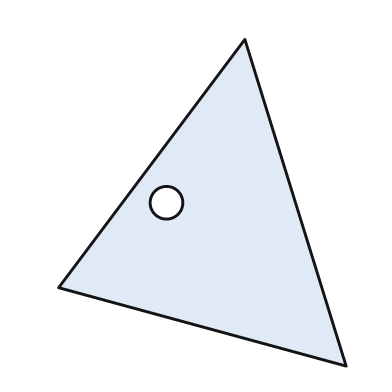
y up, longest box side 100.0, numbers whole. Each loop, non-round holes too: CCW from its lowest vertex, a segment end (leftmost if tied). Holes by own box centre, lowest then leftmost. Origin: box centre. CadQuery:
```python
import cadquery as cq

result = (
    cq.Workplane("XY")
    .moveTo(44.0, -50.0)
    .lineTo(13.0, 50.0)
    .lineTo(-44.0, -26.0)
    .close()
    .moveTo(-11.0, 0.0)
    .circle(5.0)
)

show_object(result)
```